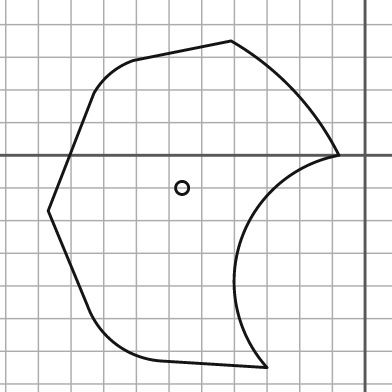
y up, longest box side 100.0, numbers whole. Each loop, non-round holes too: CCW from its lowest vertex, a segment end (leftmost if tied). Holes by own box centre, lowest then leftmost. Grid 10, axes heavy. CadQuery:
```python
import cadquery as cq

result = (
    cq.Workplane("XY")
    .moveTo(-30.0, -65.0)
    .threePointArc((-38.0, -26.0), (-8.0, 0.0))
    .threePointArc((-22.0, 20.0), (-41.0, 35.0))
    .lineTo(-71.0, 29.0)
    .threePointArc((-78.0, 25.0), (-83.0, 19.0))
    .lineTo(-97.0, -17.0)
    .lineTo(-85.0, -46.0)
    .threePointArc((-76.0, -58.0), (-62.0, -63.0))
    .close()
    .moveTo(-56.0, -10.0)
    .circle(2.0)
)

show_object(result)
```